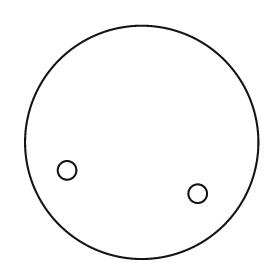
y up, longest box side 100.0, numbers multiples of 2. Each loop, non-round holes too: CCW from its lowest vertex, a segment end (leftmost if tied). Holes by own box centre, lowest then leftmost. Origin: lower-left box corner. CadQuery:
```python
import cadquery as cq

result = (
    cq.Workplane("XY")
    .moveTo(50.0, 50.0)
    .circle(50.0)
    .moveTo(74.0, 28.0)
    .circle(4.0)
    .moveTo(18.0, 38.0)
    .circle(4.0)
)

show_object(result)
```